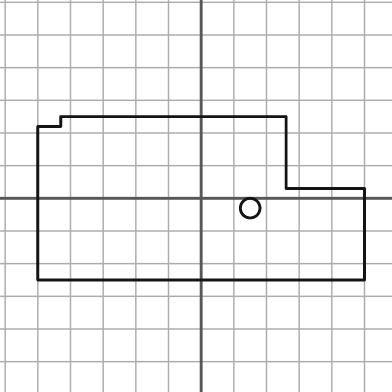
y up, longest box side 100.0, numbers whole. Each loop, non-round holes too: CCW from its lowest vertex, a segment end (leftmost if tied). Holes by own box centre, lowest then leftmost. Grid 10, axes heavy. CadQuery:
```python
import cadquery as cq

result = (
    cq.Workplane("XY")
    .moveTo(-50.0, -25.0)
    .lineTo(50.0, -25.0)
    .lineTo(50.0, 3.0)
    .lineTo(26.0, 3.0)
    .lineTo(26.0, 25.0)
    .lineTo(-43.0, 25.0)
    .lineTo(-43.0, 22.0)
    .lineTo(-50.0, 22.0)
    .close()
    .moveTo(15.0, -3.0)
    .circle(3.0)
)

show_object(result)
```